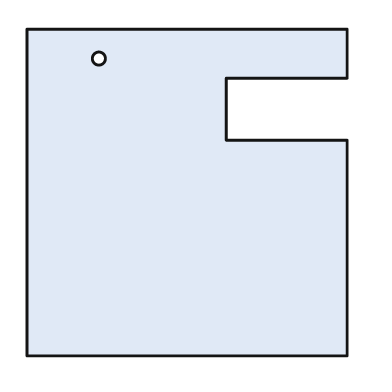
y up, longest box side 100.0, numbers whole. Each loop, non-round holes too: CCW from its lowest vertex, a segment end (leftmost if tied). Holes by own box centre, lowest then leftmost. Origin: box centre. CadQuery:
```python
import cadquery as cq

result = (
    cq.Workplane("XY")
    .moveTo(-49.0, -50.0)
    .lineTo(49.0, -50.0)
    .lineTo(49.0, 16.0)
    .lineTo(12.0, 16.0)
    .lineTo(12.0, 35.0)
    .lineTo(49.0, 35.0)
    .lineTo(49.0, 50.0)
    .lineTo(-49.0, 50.0)
    .close()
    .moveTo(-27.0, 41.0)
    .circle(2.0)
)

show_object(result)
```